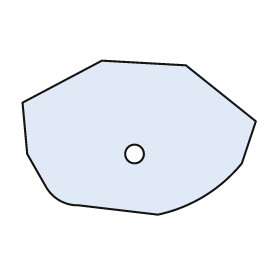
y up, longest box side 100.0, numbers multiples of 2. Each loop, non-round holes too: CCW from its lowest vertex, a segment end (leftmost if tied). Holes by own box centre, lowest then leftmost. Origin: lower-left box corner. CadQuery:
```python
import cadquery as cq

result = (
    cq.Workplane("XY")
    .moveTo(58.0, 0.0)
    .threePointArc((78.0, 8.0), (94.0, 22.0))
    .lineTo(100.0, 40.0)
    .lineTo(70.0, 64.0)
    .lineTo(34.0, 66.0)
    .lineTo(0.0, 48.0)
    .lineTo(2.0, 26.0)
    .lineTo(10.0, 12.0)
    .threePointArc((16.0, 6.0), (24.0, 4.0))
    .close()
    .moveTo(48.0, 26.0)
    .circle(4.0)
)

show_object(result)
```